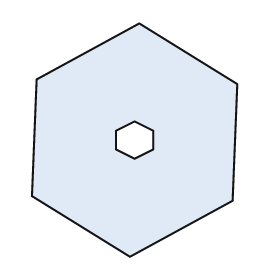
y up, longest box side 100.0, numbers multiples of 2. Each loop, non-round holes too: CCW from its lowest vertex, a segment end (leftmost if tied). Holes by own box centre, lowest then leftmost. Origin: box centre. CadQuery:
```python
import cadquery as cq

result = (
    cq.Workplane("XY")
    .moveTo(-2.0, -50.0)
    .lineTo(42.0, -26.0)
    .lineTo(44.0, 24.0)
    .lineTo(2.0, 50.0)
    .lineTo(-42.0, 26.0)
    .lineTo(-44.0, -24.0)
    .close()
    .moveTo(0.0, -8.0)
    .lineTo(8.0, -4.0)
    .lineTo(8.0, 4.0)
    .lineTo(0.0, 8.0)
    .lineTo(-8.0, 4.0)
    .lineTo(-8.0, -4.0)
    .close()
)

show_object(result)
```